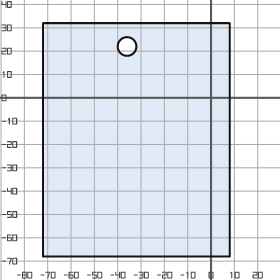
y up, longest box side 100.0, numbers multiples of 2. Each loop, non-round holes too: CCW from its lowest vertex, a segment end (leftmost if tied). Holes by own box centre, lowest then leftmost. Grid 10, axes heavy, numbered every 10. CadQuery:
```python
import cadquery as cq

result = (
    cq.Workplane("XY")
    .moveTo(-72.0, -68.0)
    .lineTo(8.0, -68.0)
    .lineTo(8.0, 32.0)
    .lineTo(-72.0, 32.0)
    .close()
    .moveTo(-36.0, 22.0)
    .circle(4.0)
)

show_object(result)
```